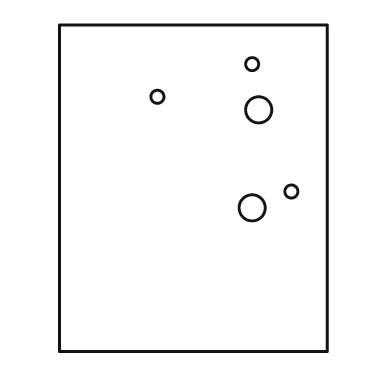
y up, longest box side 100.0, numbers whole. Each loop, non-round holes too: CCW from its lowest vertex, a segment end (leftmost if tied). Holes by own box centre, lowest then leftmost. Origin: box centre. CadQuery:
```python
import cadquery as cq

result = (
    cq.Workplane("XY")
    .moveTo(-41.0, -50.0)
    .lineTo(41.0, -50.0)
    .lineTo(41.0, 50.0)
    .lineTo(-41.0, 50.0)
    .close()
    .moveTo(18.0, -6.0)
    .circle(4.0)
    .moveTo(30.0, -1.0)
    .circle(2.0)
    .moveTo(20.0, 24.0)
    .circle(4.0)
    .moveTo(-11.0, 28.0)
    .circle(2.0)
    .moveTo(18.0, 38.0)
    .circle(2.0)
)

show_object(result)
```